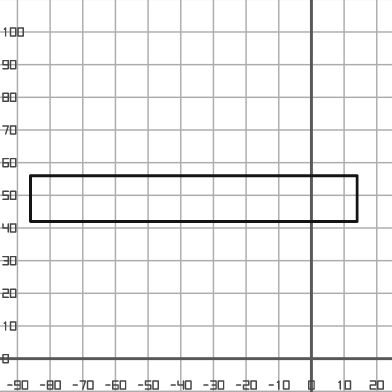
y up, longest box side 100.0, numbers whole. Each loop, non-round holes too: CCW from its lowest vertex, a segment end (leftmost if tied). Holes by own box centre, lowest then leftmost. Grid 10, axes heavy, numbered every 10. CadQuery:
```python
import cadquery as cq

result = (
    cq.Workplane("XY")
    .moveTo(-86.0, 42.0)
    .lineTo(14.0, 42.0)
    .lineTo(14.0, 56.0)
    .lineTo(-86.0, 56.0)
    .close()
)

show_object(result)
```